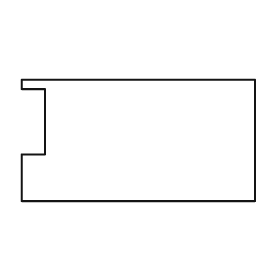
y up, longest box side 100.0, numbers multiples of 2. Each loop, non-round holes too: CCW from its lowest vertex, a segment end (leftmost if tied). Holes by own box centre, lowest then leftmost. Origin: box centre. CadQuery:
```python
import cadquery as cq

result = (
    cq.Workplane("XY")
    .moveTo(-50.0, -26.0)
    .lineTo(50.0, -26.0)
    .lineTo(50.0, 26.0)
    .lineTo(-50.0, 26.0)
    .lineTo(-50.0, 22.0)
    .lineTo(-40.0, 22.0)
    .lineTo(-40.0, -6.0)
    .lineTo(-50.0, -6.0)
    .close()
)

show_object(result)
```